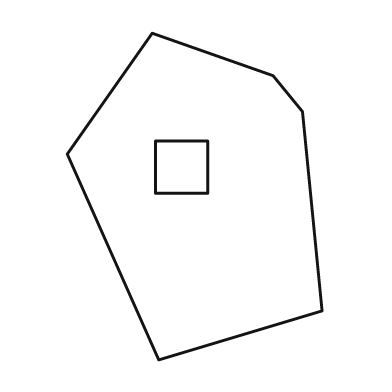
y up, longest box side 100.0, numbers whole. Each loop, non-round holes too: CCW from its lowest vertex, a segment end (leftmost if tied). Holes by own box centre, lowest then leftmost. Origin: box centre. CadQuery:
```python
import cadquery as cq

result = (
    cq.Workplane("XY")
    .moveTo(-11.0, -50.0)
    .lineTo(39.0, -35.0)
    .lineTo(33.0, 26.0)
    .lineTo(24.0, 37.0)
    .lineTo(-13.0, 50.0)
    .lineTo(-39.0, 13.0)
    .close()
    .moveTo(-12.0, 1.0)
    .lineTo(4.0, 1.0)
    .lineTo(4.0, 17.0)
    .lineTo(-12.0, 17.0)
    .close()
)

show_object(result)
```